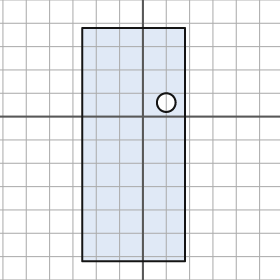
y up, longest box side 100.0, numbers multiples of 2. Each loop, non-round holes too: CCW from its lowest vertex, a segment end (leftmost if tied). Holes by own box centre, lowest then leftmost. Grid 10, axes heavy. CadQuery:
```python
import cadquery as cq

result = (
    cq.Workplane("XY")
    .moveTo(-26.0, -62.0)
    .lineTo(18.0, -62.0)
    .lineTo(18.0, 38.0)
    .lineTo(-26.0, 38.0)
    .close()
    .moveTo(10.0, 6.0)
    .circle(4.0)
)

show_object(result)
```